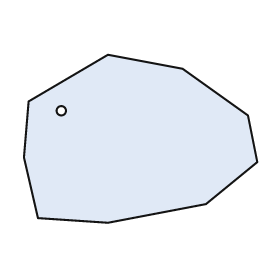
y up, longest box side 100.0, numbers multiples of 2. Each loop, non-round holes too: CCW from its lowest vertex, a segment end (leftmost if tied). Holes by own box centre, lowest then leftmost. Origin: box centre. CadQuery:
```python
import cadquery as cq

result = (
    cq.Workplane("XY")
    .moveTo(-14.0, -36.0)
    .lineTo(28.0, -28.0)
    .lineTo(50.0, -10.0)
    .lineTo(46.0, 10.0)
    .lineTo(18.0, 30.0)
    .lineTo(-14.0, 36.0)
    .lineTo(-48.0, 16.0)
    .lineTo(-50.0, -8.0)
    .lineTo(-44.0, -34.0)
    .close()
    .moveTo(-34.0, 12.0)
    .circle(2.0)
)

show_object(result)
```